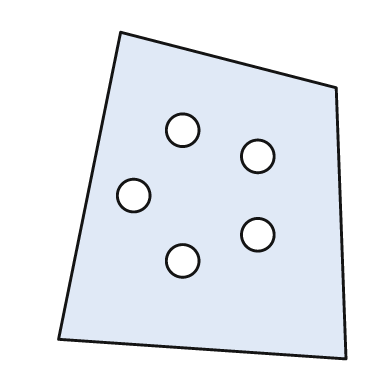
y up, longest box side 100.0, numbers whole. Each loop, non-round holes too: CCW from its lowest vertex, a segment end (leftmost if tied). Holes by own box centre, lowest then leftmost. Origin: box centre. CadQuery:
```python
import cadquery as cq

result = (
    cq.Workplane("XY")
    .moveTo(44.0, -50.0)
    .lineTo(41.0, 33.0)
    .lineTo(-25.0, 50.0)
    .lineTo(-44.0, -44.0)
    .close()
    .moveTo(-6.0, -20.0)
    .circle(5.0)
    .moveTo(17.0, -12.0)
    .circle(5.0)
    .moveTo(-21.0, 0.0)
    .circle(5.0)
    .moveTo(17.0, 12.0)
    .circle(5.0)
    .moveTo(-6.0, 20.0)
    .circle(5.0)
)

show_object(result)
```